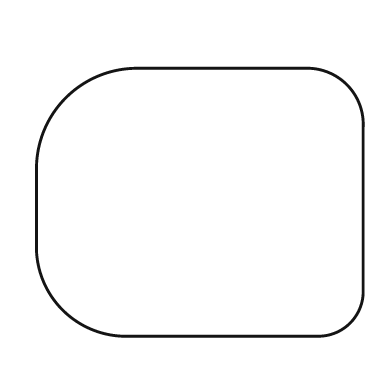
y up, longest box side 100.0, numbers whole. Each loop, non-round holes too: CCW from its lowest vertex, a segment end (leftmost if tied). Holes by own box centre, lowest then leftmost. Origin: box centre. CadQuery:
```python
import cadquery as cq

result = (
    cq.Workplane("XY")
    .moveTo(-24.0, -41.0)
    .lineTo(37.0, -41.0)
    .threePointArc((46.0, -37.0), (50.0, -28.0))
    .lineTo(50.0, 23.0)
    .threePointArc((45.0, 36.0), (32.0, 41.0))
    .lineTo(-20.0, 41.0)
    .threePointArc((-41.0, 32.0), (-50.0, 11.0))
    .lineTo(-50.0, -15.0)
    .threePointArc((-42.0, -33.0), (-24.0, -41.0))
    .close()
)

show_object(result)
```